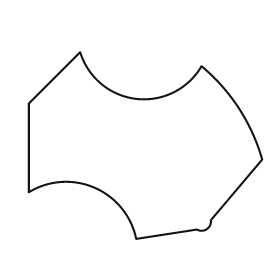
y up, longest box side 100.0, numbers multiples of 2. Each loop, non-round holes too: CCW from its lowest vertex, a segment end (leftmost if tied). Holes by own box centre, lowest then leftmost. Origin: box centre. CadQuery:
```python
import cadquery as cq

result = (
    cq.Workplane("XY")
    .moveTo(-4.0, -40.0)
    .lineTo(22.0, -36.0)
    .threePointArc((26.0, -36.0), (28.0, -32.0))
    .lineTo(50.0, -6.0)
    .threePointArc((40.0, 16.0), (24.0, 34.0))
    .threePointArc((-4.0, 20.0), (-28.0, 40.0))
    .lineTo(-50.0, 18.0)
    .lineTo(-50.0, -20.0)
    .threePointArc((-22.0, -18.0), (-4.0, -40.0))
    .close()
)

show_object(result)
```